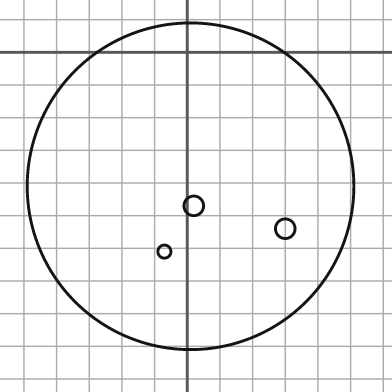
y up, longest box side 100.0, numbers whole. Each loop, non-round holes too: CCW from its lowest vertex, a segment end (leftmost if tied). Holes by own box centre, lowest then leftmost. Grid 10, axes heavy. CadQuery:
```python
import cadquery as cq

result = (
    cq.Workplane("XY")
    .moveTo(1.0, -41.0)
    .circle(50.0)
    .moveTo(-7.0, -61.0)
    .circle(2.0)
    .moveTo(30.0, -54.0)
    .circle(3.0)
    .moveTo(2.0, -47.0)
    .circle(3.0)
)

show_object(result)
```